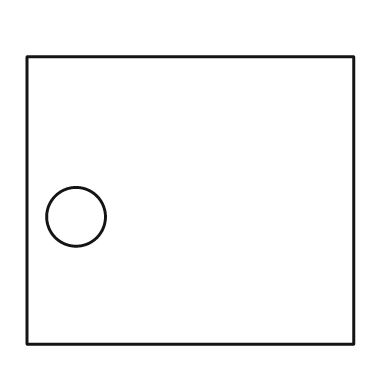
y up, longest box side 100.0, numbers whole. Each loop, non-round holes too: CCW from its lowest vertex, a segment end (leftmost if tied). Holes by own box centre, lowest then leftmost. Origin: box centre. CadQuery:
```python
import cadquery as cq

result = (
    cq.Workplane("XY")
    .moveTo(-50.0, -44.0)
    .lineTo(50.0, -44.0)
    .lineTo(50.0, 44.0)
    .lineTo(-50.0, 44.0)
    .close()
    .moveTo(-35.0, -5.0)
    .circle(9.0)
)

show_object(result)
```